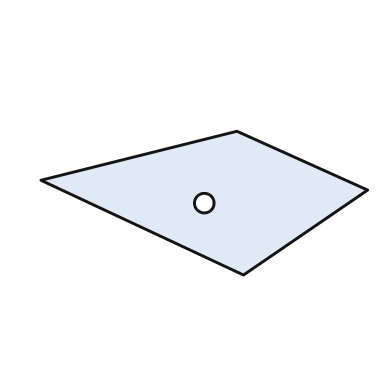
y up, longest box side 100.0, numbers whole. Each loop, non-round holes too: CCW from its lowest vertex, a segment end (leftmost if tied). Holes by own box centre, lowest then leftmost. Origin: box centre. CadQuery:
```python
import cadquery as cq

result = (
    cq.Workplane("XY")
    .moveTo(12.0, -22.0)
    .lineTo(50.0, 4.0)
    .lineTo(10.0, 22.0)
    .lineTo(-50.0, 7.0)
    .close()
    .moveTo(0.0, 0.0)
    .circle(3.0)
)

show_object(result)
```